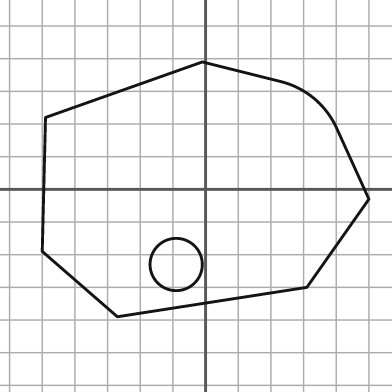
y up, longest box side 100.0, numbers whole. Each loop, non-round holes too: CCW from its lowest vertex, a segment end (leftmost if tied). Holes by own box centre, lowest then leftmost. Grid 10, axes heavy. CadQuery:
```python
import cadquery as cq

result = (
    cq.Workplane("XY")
    .moveTo(-27.0, -39.0)
    .lineTo(31.0, -30.0)
    .lineTo(50.0, -3.0)
    .lineTo(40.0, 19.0)
    .threePointArc((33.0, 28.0), (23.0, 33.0))
    .lineTo(-1.0, 39.0)
    .lineTo(-49.0, 22.0)
    .lineTo(-50.0, -19.0)
    .close()
    .moveTo(-9.0, -23.0)
    .circle(8.0)
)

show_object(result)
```